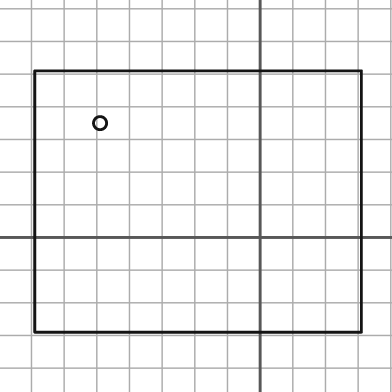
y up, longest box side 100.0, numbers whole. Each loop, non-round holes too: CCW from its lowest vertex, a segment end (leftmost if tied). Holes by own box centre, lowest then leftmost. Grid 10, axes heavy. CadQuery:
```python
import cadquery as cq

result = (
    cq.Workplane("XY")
    .moveTo(-69.0, -29.0)
    .lineTo(31.0, -29.0)
    .lineTo(31.0, 51.0)
    .lineTo(-69.0, 51.0)
    .close()
    .moveTo(-49.0, 35.0)
    .circle(2.0)
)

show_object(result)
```